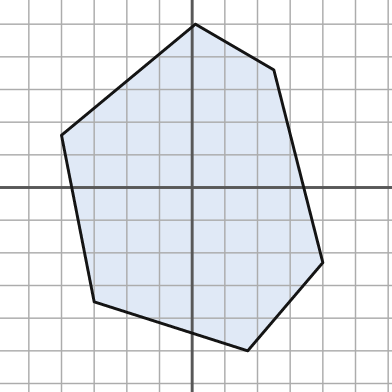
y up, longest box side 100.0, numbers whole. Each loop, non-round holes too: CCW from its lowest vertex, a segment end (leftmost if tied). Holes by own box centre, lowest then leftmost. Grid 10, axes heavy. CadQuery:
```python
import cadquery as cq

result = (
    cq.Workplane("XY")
    .moveTo(17.0, -50.0)
    .lineTo(40.0, -23.0)
    .lineTo(25.0, 36.0)
    .lineTo(1.0, 50.0)
    .lineTo(-40.0, 16.0)
    .lineTo(-30.0, -35.0)
    .close()
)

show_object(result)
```